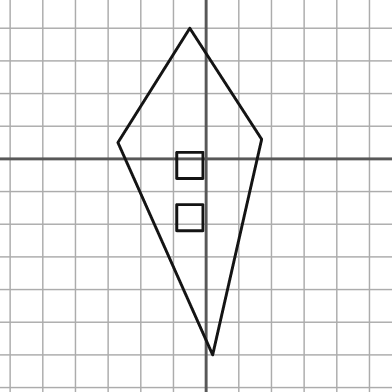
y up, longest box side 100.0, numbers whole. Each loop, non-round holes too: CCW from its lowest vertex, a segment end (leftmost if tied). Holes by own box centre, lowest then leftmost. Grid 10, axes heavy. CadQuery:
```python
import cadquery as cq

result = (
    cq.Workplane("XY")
    .moveTo(2.0, -60.0)
    .lineTo(17.0, 6.0)
    .lineTo(-5.0, 40.0)
    .lineTo(-27.0, 5.0)
    .close()
    .moveTo(-9.0, -22.0)
    .lineTo(-1.0, -22.0)
    .lineTo(-1.0, -14.0)
    .lineTo(-9.0, -14.0)
    .close()
    .moveTo(-9.0, -6.0)
    .lineTo(-1.0, -6.0)
    .lineTo(-1.0, 2.0)
    .lineTo(-9.0, 2.0)
    .close()
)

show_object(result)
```